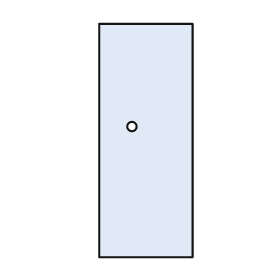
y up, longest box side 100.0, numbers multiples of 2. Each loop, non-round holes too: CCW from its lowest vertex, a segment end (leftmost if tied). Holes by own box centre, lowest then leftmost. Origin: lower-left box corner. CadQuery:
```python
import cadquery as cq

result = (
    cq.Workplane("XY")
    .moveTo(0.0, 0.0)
    .lineTo(40.0, 0.0)
    .lineTo(40.0, 100.0)
    .lineTo(0.0, 100.0)
    .close()
    .moveTo(14.0, 56.0)
    .circle(2.0)
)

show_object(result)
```